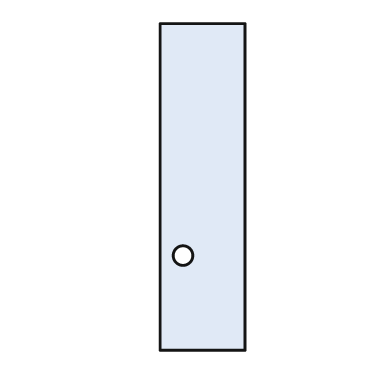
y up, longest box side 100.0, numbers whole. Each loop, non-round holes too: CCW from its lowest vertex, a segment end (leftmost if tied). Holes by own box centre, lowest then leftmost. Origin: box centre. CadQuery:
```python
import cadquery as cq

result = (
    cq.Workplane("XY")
    .moveTo(-13.0, -50.0)
    .lineTo(13.0, -50.0)
    .lineTo(13.0, 50.0)
    .lineTo(-13.0, 50.0)
    .close()
    .moveTo(-6.0, -21.0)
    .circle(3.0)
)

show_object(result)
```